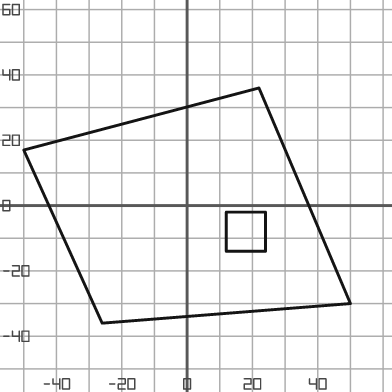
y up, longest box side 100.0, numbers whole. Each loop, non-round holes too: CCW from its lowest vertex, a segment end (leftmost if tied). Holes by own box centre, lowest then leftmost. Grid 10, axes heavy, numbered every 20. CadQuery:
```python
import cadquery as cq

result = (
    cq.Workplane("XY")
    .moveTo(-26.0, -36.0)
    .lineTo(50.0, -30.0)
    .lineTo(22.0, 36.0)
    .lineTo(-50.0, 17.0)
    .close()
    .moveTo(12.0, -14.0)
    .lineTo(24.0, -14.0)
    .lineTo(24.0, -2.0)
    .lineTo(12.0, -2.0)
    .close()
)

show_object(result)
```